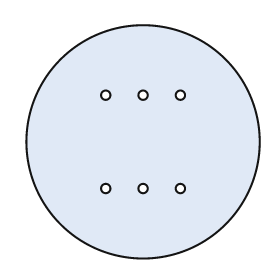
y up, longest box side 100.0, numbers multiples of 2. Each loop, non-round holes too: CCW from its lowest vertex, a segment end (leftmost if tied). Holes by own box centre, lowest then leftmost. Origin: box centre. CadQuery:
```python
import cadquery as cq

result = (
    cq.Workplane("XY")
    .moveTo(0.0, 0.0)
    .circle(50.0)
    .moveTo(-16.0, -20.0)
    .circle(2.0)
    .moveTo(0.0, -20.0)
    .circle(2.0)
    .moveTo(16.0, -20.0)
    .circle(2.0)
    .moveTo(-16.0, 20.0)
    .circle(2.0)
    .moveTo(0.0, 20.0)
    .circle(2.0)
    .moveTo(16.0, 20.0)
    .circle(2.0)
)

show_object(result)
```